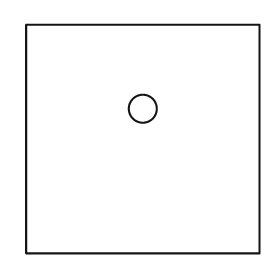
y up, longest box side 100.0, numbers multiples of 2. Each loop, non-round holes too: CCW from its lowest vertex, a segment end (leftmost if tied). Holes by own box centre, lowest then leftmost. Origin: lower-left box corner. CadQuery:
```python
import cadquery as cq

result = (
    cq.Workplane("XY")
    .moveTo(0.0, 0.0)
    .lineTo(100.0, 0.0)
    .lineTo(100.0, 98.0)
    .lineTo(0.0, 98.0)
    .close()
    .moveTo(50.0, 62.0)
    .circle(6.0)
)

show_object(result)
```